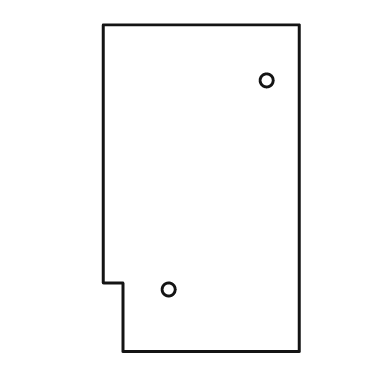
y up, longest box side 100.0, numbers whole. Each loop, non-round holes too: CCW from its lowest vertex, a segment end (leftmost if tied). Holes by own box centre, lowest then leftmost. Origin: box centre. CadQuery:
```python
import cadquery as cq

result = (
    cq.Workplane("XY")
    .moveTo(-24.0, -50.0)
    .lineTo(30.0, -50.0)
    .lineTo(30.0, 50.0)
    .lineTo(-30.0, 50.0)
    .lineTo(-30.0, -29.0)
    .lineTo(-24.0, -29.0)
    .close()
    .moveTo(-10.0, -31.0)
    .circle(2.0)
    .moveTo(20.0, 33.0)
    .circle(2.0)
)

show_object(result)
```